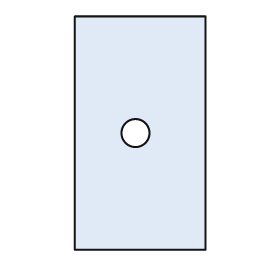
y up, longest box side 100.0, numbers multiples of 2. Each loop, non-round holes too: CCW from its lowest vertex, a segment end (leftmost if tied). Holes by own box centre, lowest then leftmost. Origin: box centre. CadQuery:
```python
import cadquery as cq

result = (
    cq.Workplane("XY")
    .moveTo(-28.0, -50.0)
    .lineTo(28.0, -50.0)
    .lineTo(28.0, 50.0)
    .lineTo(-28.0, 50.0)
    .close()
    .moveTo(-2.0, 0.0)
    .circle(6.0)
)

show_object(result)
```